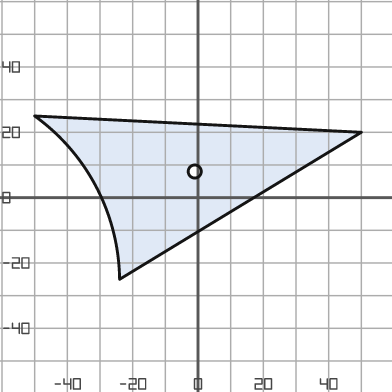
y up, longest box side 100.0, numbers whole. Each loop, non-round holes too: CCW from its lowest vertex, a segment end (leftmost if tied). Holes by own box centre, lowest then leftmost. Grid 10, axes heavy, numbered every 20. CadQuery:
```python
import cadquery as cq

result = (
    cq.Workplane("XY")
    .moveTo(-24.0, -25.0)
    .lineTo(50.0, 20.0)
    .lineTo(-50.0, 25.0)
    .threePointArc((-31.0, 3.0), (-24.0, -25.0))
    .close()
    .moveTo(-1.0, 8.0)
    .circle(2.0)
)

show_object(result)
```